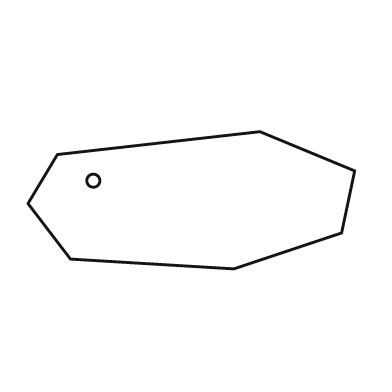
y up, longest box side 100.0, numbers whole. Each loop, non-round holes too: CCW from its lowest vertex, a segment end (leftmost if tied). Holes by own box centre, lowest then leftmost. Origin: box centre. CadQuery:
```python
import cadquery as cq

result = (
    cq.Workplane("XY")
    .moveTo(13.0, -21.0)
    .lineTo(46.0, -10.0)
    .lineTo(50.0, 9.0)
    .lineTo(21.0, 21.0)
    .lineTo(-41.0, 14.0)
    .lineTo(-50.0, -1.0)
    .lineTo(-37.0, -18.0)
    .close()
    .moveTo(-30.0, 6.0)
    .circle(2.0)
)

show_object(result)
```